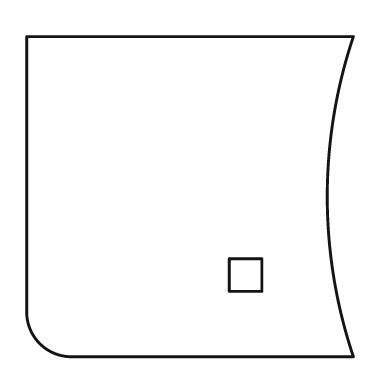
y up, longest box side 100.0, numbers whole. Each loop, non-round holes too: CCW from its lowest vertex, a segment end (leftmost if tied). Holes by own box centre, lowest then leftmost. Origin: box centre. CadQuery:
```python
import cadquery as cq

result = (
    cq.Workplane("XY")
    .moveTo(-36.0, -49.0)
    .lineTo(50.0, -49.0)
    .threePointArc((42.0, 0.0), (50.0, 49.0))
    .lineTo(-50.0, 49.0)
    .lineTo(-50.0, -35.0)
    .threePointArc((-46.0, -45.0), (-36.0, -49.0))
    .close()
    .moveTo(12.0, -29.0)
    .lineTo(22.0, -29.0)
    .lineTo(22.0, -19.0)
    .lineTo(12.0, -19.0)
    .close()
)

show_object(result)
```